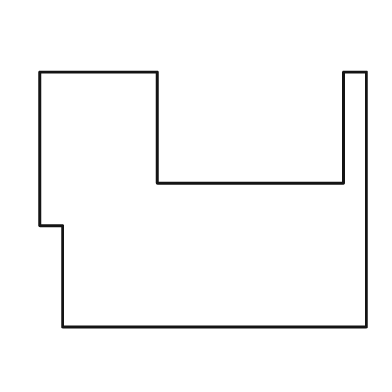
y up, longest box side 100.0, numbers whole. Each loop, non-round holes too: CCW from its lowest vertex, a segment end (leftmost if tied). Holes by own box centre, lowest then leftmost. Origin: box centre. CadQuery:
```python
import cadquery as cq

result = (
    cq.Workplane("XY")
    .moveTo(-43.0, -39.0)
    .lineTo(50.0, -39.0)
    .lineTo(50.0, 39.0)
    .lineTo(43.0, 39.0)
    .lineTo(43.0, 5.0)
    .lineTo(-14.0, 5.0)
    .lineTo(-14.0, 39.0)
    .lineTo(-50.0, 39.0)
    .lineTo(-50.0, -8.0)
    .lineTo(-43.0, -8.0)
    .close()
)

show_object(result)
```